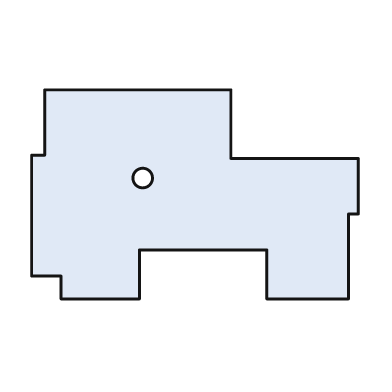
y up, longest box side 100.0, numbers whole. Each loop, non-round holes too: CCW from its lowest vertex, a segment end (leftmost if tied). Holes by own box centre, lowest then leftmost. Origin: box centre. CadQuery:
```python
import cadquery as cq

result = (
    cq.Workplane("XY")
    .moveTo(-41.0, -32.0)
    .lineTo(-17.0, -32.0)
    .lineTo(-17.0, -17.0)
    .lineTo(22.0, -17.0)
    .lineTo(22.0, -32.0)
    .lineTo(47.0, -32.0)
    .lineTo(47.0, -6.0)
    .lineTo(50.0, -6.0)
    .lineTo(50.0, 11.0)
    .lineTo(11.0, 11.0)
    .lineTo(11.0, 32.0)
    .lineTo(-46.0, 32.0)
    .lineTo(-46.0, 12.0)
    .lineTo(-50.0, 12.0)
    .lineTo(-50.0, -25.0)
    .lineTo(-41.0, -25.0)
    .close()
    .moveTo(-16.0, 5.0)
    .circle(3.0)
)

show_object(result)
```